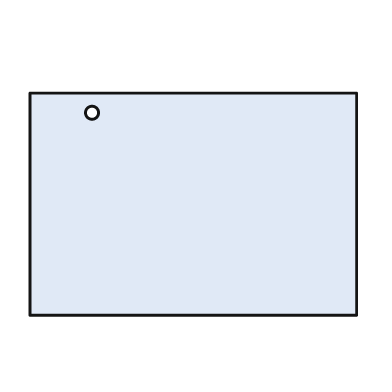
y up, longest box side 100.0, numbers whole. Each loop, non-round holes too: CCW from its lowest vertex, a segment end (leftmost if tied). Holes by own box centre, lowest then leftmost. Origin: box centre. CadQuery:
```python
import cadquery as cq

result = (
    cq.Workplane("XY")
    .moveTo(-50.0, -34.0)
    .lineTo(50.0, -34.0)
    .lineTo(50.0, 34.0)
    .lineTo(-50.0, 34.0)
    .close()
    .moveTo(-31.0, 28.0)
    .circle(2.0)
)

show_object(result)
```